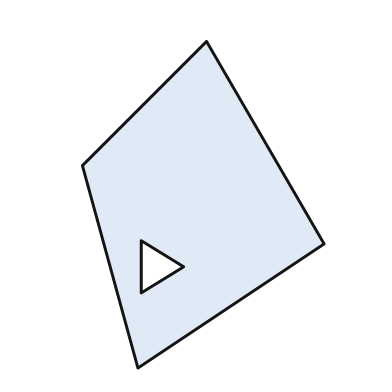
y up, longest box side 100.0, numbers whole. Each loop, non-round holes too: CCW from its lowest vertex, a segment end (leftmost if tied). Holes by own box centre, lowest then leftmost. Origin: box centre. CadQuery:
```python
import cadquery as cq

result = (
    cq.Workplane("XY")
    .moveTo(-20.0, -50.0)
    .lineTo(37.0, -12.0)
    .lineTo(1.0, 50.0)
    .lineTo(-37.0, 12.0)
    .close()
    .moveTo(-19.0, -27.0)
    .lineTo(-6.0, -19.0)
    .lineTo(-19.0, -11.0)
    .close()
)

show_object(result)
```